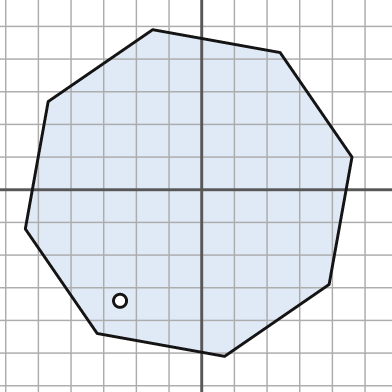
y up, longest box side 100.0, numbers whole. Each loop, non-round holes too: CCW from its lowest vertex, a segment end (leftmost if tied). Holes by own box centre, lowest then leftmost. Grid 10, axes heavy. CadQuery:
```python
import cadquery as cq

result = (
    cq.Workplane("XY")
    .moveTo(7.0, -51.0)
    .lineTo(39.0, -29.0)
    .lineTo(46.0, 10.0)
    .lineTo(24.0, 42.0)
    .lineTo(-15.0, 49.0)
    .lineTo(-47.0, 27.0)
    .lineTo(-54.0, -12.0)
    .lineTo(-32.0, -44.0)
    .close()
    .moveTo(-25.0, -34.0)
    .circle(2.0)
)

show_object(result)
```